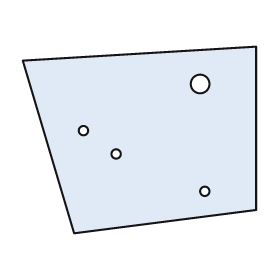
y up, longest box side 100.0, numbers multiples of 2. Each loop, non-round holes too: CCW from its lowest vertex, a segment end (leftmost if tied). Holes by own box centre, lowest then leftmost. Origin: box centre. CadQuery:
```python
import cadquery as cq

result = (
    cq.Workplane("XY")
    .moveTo(-28.0, -40.0)
    .lineTo(50.0, -30.0)
    .lineTo(50.0, 40.0)
    .lineTo(-50.0, 34.0)
    .close()
    .moveTo(28.0, -22.0)
    .circle(2.0)
    .moveTo(-10.0, -6.0)
    .circle(2.0)
    .moveTo(-24.0, 4.0)
    .circle(2.0)
    .moveTo(26.0, 24.0)
    .circle(4.0)
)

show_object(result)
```